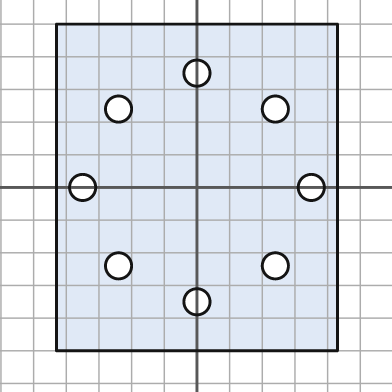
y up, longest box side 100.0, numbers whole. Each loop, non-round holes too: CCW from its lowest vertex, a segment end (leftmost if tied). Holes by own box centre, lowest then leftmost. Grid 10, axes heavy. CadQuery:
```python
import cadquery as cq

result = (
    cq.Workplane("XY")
    .moveTo(-43.0, -50.0)
    .lineTo(43.0, -50.0)
    .lineTo(43.0, 50.0)
    .lineTo(-43.0, 50.0)
    .close()
    .moveTo(0.0, -35.0)
    .circle(4.0)
    .moveTo(-24.0, -24.0)
    .circle(4.0)
    .moveTo(24.0, -24.0)
    .circle(4.0)
    .moveTo(-35.0, 0.0)
    .circle(4.0)
    .moveTo(35.0, 0.0)
    .circle(4.0)
    .moveTo(-24.0, 24.0)
    .circle(4.0)
    .moveTo(24.0, 24.0)
    .circle(4.0)
    .moveTo(0.0, 35.0)
    .circle(4.0)
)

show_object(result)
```